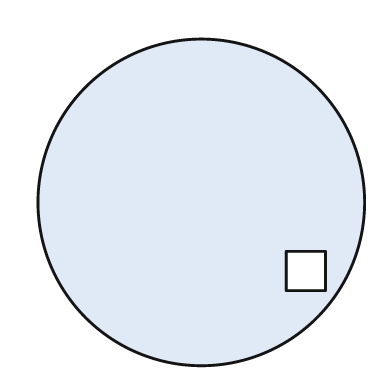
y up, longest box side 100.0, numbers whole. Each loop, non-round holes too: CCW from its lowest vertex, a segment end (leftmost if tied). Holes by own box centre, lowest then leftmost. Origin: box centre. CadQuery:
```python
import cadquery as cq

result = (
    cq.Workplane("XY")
    .moveTo(0.0, 0.0)
    .circle(50.0)
    .moveTo(26.0, -27.0)
    .lineTo(38.0, -27.0)
    .lineTo(38.0, -15.0)
    .lineTo(26.0, -15.0)
    .close()
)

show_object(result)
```